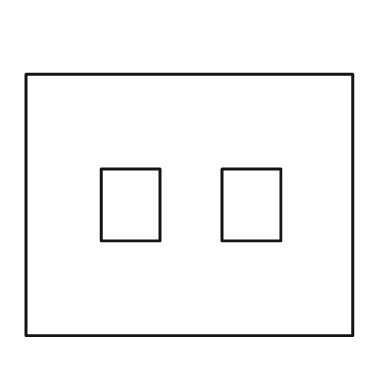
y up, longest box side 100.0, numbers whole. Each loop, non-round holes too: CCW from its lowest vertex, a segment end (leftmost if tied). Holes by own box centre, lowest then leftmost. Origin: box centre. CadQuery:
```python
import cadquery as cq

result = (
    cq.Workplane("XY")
    .moveTo(-50.0, -40.0)
    .lineTo(50.0, -40.0)
    .lineTo(50.0, 40.0)
    .lineTo(-50.0, 40.0)
    .close()
    .moveTo(-27.0, -11.0)
    .lineTo(-9.0, -11.0)
    .lineTo(-9.0, 11.0)
    .lineTo(-27.0, 11.0)
    .close()
    .moveTo(10.0, -11.0)
    .lineTo(28.0, -11.0)
    .lineTo(28.0, 11.0)
    .lineTo(10.0, 11.0)
    .close()
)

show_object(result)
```